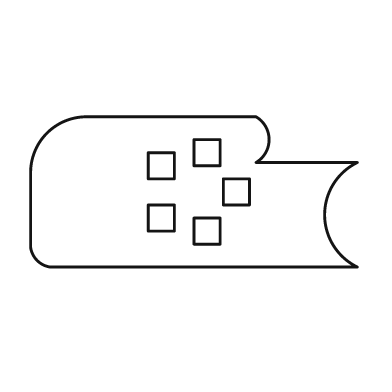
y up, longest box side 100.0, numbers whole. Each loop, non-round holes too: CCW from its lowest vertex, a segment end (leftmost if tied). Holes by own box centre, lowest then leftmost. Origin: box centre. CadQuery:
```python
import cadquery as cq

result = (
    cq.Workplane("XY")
    .moveTo(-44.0, -23.0)
    .lineTo(50.0, -23.0)
    .threePointArc((40.0, -7.0), (50.0, 9.0))
    .lineTo(19.0, 9.0)
    .threePointArc((23.0, 16.0), (19.0, 23.0))
    .lineTo(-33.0, 23.0)
    .threePointArc((-45.0, 18.0), (-50.0, 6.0))
    .lineTo(-50.0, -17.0)
    .threePointArc((-48.0, -21.0), (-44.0, -23.0))
    .close()
    .moveTo(0.0, -16.0)
    .lineTo(8.0, -16.0)
    .lineTo(8.0, -8.0)
    .lineTo(0.0, -8.0)
    .close()
    .moveTo(-14.0, -12.0)
    .lineTo(-6.0, -12.0)
    .lineTo(-6.0, -4.0)
    .lineTo(-14.0, -4.0)
    .close()
    .moveTo(9.0, -4.0)
    .lineTo(17.0, -4.0)
    .lineTo(17.0, 4.0)
    .lineTo(9.0, 4.0)
    .close()
    .moveTo(-14.0, 4.0)
    .lineTo(-6.0, 4.0)
    .lineTo(-6.0, 12.0)
    .lineTo(-14.0, 12.0)
    .close()
    .moveTo(0.0, 8.0)
    .lineTo(8.0, 8.0)
    .lineTo(8.0, 16.0)
    .lineTo(0.0, 16.0)
    .close()
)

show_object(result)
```